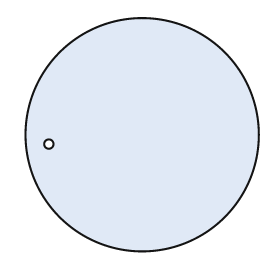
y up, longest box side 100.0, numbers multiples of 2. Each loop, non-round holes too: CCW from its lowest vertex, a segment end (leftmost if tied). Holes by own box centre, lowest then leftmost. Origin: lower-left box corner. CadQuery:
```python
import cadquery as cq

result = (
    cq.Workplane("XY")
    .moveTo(50.0, 50.0)
    .circle(50.0)
    .moveTo(10.0, 46.0)
    .circle(2.0)
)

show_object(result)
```